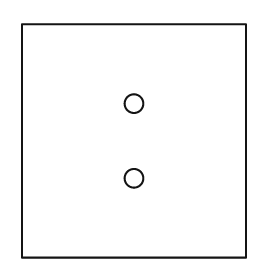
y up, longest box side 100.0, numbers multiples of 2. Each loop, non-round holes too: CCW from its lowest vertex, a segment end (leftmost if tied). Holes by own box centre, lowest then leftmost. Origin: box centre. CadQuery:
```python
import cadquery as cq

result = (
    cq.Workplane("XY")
    .moveTo(-48.0, -50.0)
    .lineTo(48.0, -50.0)
    .lineTo(48.0, 50.0)
    .lineTo(-48.0, 50.0)
    .close()
    .moveTo(0.0, -16.0)
    .circle(4.0)
    .moveTo(0.0, 16.0)
    .circle(4.0)
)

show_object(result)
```